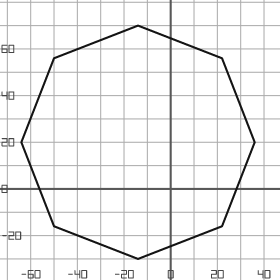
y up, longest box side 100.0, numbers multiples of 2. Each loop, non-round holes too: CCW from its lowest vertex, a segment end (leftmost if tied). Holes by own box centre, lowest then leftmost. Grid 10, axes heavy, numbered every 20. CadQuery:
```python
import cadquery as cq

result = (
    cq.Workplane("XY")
    .moveTo(-14.0, -30.0)
    .lineTo(22.0, -16.0)
    .lineTo(36.0, 20.0)
    .lineTo(22.0, 56.0)
    .lineTo(-14.0, 70.0)
    .lineTo(-50.0, 56.0)
    .lineTo(-64.0, 20.0)
    .lineTo(-50.0, -16.0)
    .close()
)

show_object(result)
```